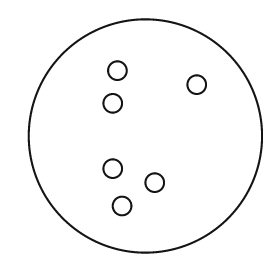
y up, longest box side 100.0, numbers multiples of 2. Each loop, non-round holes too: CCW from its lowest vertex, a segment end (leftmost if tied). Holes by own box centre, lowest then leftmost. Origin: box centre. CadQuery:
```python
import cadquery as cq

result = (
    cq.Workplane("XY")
    .moveTo(0.0, 0.0)
    .circle(50.0)
    .moveTo(-10.0, -30.0)
    .circle(4.0)
    .moveTo(4.0, -20.0)
    .circle(4.0)
    .moveTo(-14.0, -14.0)
    .circle(4.0)
    .moveTo(-14.0, 14.0)
    .circle(4.0)
    .moveTo(22.0, 22.0)
    .circle(4.0)
    .moveTo(-12.0, 28.0)
    .circle(4.0)
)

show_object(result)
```